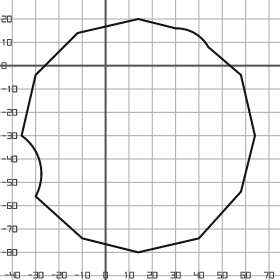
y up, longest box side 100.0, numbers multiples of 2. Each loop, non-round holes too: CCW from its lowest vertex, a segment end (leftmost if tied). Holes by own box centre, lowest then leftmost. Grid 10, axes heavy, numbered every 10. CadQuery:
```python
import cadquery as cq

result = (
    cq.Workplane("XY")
    .moveTo(14.0, -80.0)
    .lineTo(40.0, -74.0)
    .lineTo(58.0, -54.0)
    .lineTo(64.0, -30.0)
    .lineTo(58.0, -4.0)
    .lineTo(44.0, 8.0)
    .threePointArc((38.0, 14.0), (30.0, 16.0))
    .lineTo(14.0, 20.0)
    .lineTo(-12.0, 14.0)
    .lineTo(-30.0, -4.0)
    .lineTo(-36.0, -30.0)
    .threePointArc((-28.0, -42.0), (-30.0, -56.0))
    .lineTo(-10.0, -74.0)
    .close()
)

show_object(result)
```